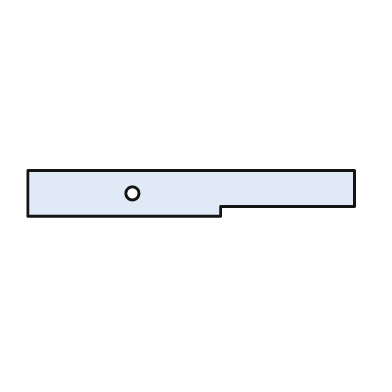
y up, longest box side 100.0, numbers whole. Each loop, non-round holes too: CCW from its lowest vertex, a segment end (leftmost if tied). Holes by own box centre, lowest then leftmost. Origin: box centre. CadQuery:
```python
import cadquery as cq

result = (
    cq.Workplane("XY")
    .moveTo(-50.0, -7.0)
    .lineTo(9.0, -7.0)
    .lineTo(9.0, -4.0)
    .lineTo(50.0, -4.0)
    .lineTo(50.0, 7.0)
    .lineTo(-50.0, 7.0)
    .close()
    .moveTo(-18.0, 0.0)
    .circle(2.0)
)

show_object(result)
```